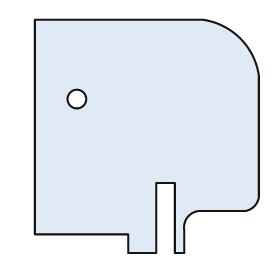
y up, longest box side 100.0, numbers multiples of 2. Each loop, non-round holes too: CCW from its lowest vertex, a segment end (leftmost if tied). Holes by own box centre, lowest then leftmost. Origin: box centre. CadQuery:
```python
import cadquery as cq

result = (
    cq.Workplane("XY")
    .moveTo(-8.0, -50.0)
    .lineTo(4.0, -50.0)
    .lineTo(4.0, -20.0)
    .lineTo(12.0, -20.0)
    .lineTo(12.0, -50.0)
    .lineTo(16.0, -50.0)
    .lineTo(16.0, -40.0)
    .threePointArc((18.0, -34.0), (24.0, -32.0))
    .lineTo(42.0, -32.0)
    .threePointArc((46.0, -30.0), (48.0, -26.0))
    .lineTo(48.0, 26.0)
    .threePointArc((40.0, 42.0), (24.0, 50.0))
    .lineTo(-48.0, 50.0)
    .lineTo(-48.0, -42.0)
    .lineTo(-8.0, -42.0)
    .close()
    .moveTo(-30.0, 16.0)
    .circle(4.0)
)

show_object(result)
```